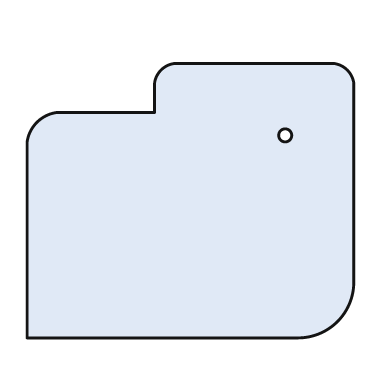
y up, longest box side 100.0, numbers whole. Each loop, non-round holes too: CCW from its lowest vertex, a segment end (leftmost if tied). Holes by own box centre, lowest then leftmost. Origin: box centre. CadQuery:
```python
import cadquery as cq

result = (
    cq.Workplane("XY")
    .moveTo(-50.0, -42.0)
    .lineTo(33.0, -42.0)
    .threePointArc((45.0, -37.0), (50.0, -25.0))
    .lineTo(50.0, 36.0)
    .threePointArc((48.0, 40.0), (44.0, 42.0))
    .lineTo(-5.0, 42.0)
    .threePointArc((-9.0, 40.0), (-11.0, 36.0))
    .lineTo(-11.0, 27.0)
    .lineTo(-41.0, 27.0)
    .threePointArc((-47.0, 24.0), (-50.0, 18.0))
    .close()
    .moveTo(29.0, 20.0)
    .circle(2.0)
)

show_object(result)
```